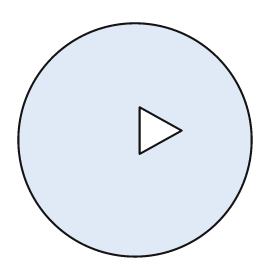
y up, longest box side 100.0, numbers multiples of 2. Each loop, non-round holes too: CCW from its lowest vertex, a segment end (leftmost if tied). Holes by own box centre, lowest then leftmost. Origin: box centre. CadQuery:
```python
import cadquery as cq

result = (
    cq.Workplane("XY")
    .moveTo(0.0, 0.0)
    .circle(50.0)
    .moveTo(2.0, -6.0)
    .lineTo(20.0, 4.0)
    .lineTo(2.0, 14.0)
    .close()
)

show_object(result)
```